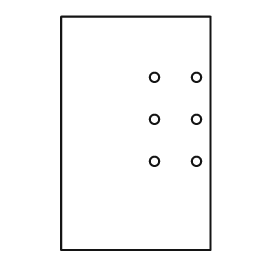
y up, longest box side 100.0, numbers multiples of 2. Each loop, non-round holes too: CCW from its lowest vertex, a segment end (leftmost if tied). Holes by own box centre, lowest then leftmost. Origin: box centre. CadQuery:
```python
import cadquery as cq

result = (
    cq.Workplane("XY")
    .moveTo(-32.0, -50.0)
    .lineTo(32.0, -50.0)
    .lineTo(32.0, 50.0)
    .lineTo(-32.0, 50.0)
    .close()
    .moveTo(8.0, -12.0)
    .circle(2.0)
    .moveTo(26.0, -12.0)
    .circle(2.0)
    .moveTo(8.0, 6.0)
    .circle(2.0)
    .moveTo(26.0, 6.0)
    .circle(2.0)
    .moveTo(8.0, 24.0)
    .circle(2.0)
    .moveTo(26.0, 24.0)
    .circle(2.0)
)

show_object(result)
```